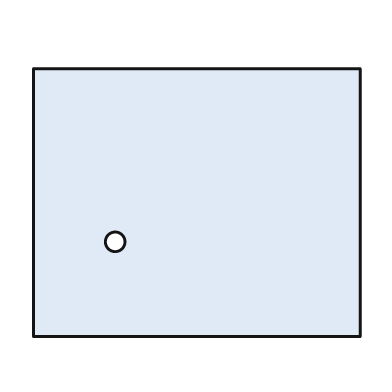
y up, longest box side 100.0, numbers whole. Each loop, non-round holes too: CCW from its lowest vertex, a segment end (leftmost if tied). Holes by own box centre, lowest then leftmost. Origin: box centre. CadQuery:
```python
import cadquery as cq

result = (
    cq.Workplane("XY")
    .moveTo(-50.0, -41.0)
    .lineTo(50.0, -41.0)
    .lineTo(50.0, 41.0)
    .lineTo(-50.0, 41.0)
    .close()
    .moveTo(-25.0, -12.0)
    .circle(3.0)
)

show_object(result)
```